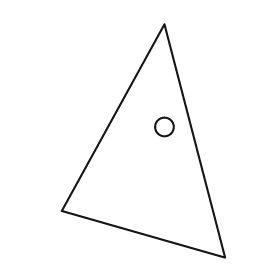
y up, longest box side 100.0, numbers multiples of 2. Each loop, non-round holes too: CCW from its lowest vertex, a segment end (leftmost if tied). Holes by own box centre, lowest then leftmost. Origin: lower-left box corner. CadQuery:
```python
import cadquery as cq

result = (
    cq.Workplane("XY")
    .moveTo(70.0, 0.0)
    .lineTo(44.0, 100.0)
    .lineTo(0.0, 20.0)
    .close()
    .moveTo(44.0, 56.0)
    .circle(4.0)
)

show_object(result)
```